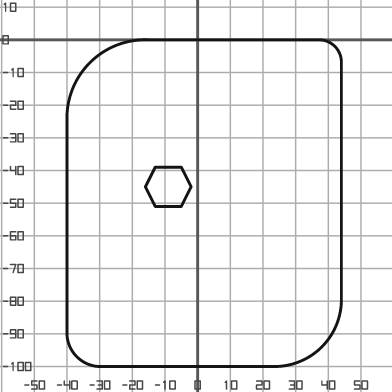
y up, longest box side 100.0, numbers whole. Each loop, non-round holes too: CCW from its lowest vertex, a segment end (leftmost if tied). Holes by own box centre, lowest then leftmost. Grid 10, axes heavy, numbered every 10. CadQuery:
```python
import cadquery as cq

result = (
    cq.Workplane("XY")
    .moveTo(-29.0, -100.0)
    .lineTo(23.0, -100.0)
    .threePointArc((38.0, -94.0), (44.0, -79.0))
    .lineTo(44.0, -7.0)
    .threePointArc((42.0, -2.0), (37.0, 0.0))
    .lineTo(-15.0, 0.0)
    .threePointArc((-33.0, -7.0), (-40.0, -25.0))
    .lineTo(-40.0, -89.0)
    .threePointArc((-37.0, -97.0), (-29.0, -100.0))
    .close()
    .moveTo(-13.0, -51.0)
    .lineTo(-5.0, -51.0)
    .lineTo(-2.0, -45.0)
    .lineTo(-5.0, -39.0)
    .lineTo(-13.0, -39.0)
    .lineTo(-16.0, -45.0)
    .close()
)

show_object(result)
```